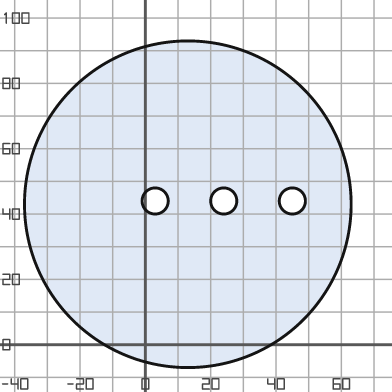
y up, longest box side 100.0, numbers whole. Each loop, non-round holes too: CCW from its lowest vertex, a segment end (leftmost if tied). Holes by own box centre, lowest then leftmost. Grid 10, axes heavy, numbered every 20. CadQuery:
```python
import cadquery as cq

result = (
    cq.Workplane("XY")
    .moveTo(13.0, 43.0)
    .circle(50.0)
    .moveTo(3.0, 44.0)
    .circle(4.0)
    .moveTo(24.0, 44.0)
    .circle(4.0)
    .moveTo(45.0, 44.0)
    .circle(4.0)
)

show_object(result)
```